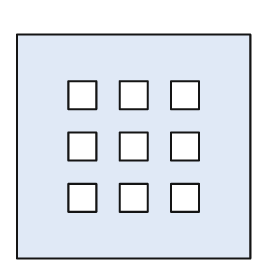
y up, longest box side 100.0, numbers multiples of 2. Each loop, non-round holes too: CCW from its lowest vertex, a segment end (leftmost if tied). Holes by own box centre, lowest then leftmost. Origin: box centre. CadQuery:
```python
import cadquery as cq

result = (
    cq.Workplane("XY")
    .moveTo(-50.0, -48.0)
    .lineTo(50.0, -48.0)
    .lineTo(50.0, 48.0)
    .lineTo(-50.0, 48.0)
    .close()
    .moveTo(-28.0, -28.0)
    .lineTo(-16.0, -28.0)
    .lineTo(-16.0, -16.0)
    .lineTo(-28.0, -16.0)
    .close()
    .moveTo(-6.0, -28.0)
    .lineTo(6.0, -28.0)
    .lineTo(6.0, -16.0)
    .lineTo(-6.0, -16.0)
    .close()
    .moveTo(16.0, -28.0)
    .lineTo(28.0, -28.0)
    .lineTo(28.0, -16.0)
    .lineTo(16.0, -16.0)
    .close()
    .moveTo(-28.0, -6.0)
    .lineTo(-16.0, -6.0)
    .lineTo(-16.0, 6.0)
    .lineTo(-28.0, 6.0)
    .close()
    .moveTo(-6.0, -6.0)
    .lineTo(6.0, -6.0)
    .lineTo(6.0, 6.0)
    .lineTo(-6.0, 6.0)
    .close()
    .moveTo(16.0, -6.0)
    .lineTo(28.0, -6.0)
    .lineTo(28.0, 6.0)
    .lineTo(16.0, 6.0)
    .close()
    .moveTo(-28.0, 16.0)
    .lineTo(-16.0, 16.0)
    .lineTo(-16.0, 28.0)
    .lineTo(-28.0, 28.0)
    .close()
    .moveTo(-6.0, 16.0)
    .lineTo(6.0, 16.0)
    .lineTo(6.0, 28.0)
    .lineTo(-6.0, 28.0)
    .close()
    .moveTo(16.0, 16.0)
    .lineTo(28.0, 16.0)
    .lineTo(28.0, 28.0)
    .lineTo(16.0, 28.0)
    .close()
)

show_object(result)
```